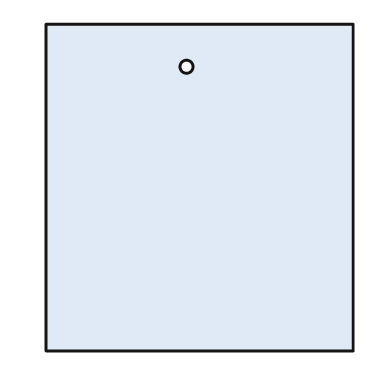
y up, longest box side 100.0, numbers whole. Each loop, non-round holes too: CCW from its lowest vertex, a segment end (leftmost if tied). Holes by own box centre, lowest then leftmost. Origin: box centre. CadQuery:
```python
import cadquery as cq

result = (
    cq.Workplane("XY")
    .moveTo(-47.0, -50.0)
    .lineTo(47.0, -50.0)
    .lineTo(47.0, 50.0)
    .lineTo(-47.0, 50.0)
    .close()
    .moveTo(-4.0, 37.0)
    .circle(2.0)
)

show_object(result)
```